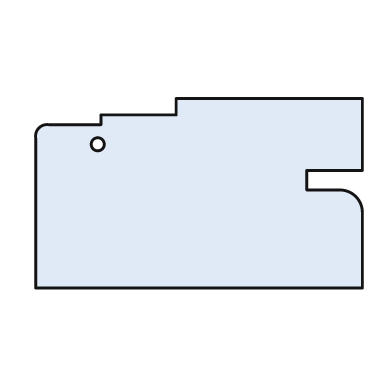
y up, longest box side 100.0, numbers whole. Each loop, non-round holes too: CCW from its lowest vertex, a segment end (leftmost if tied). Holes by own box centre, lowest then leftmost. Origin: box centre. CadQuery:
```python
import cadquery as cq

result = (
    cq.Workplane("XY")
    .moveTo(-50.0, -29.0)
    .lineTo(50.0, -29.0)
    .lineTo(50.0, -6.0)
    .threePointArc((48.0, -1.0), (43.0, 1.0))
    .lineTo(33.0, 1.0)
    .lineTo(33.0, 7.0)
    .lineTo(50.0, 7.0)
    .lineTo(50.0, 29.0)
    .lineTo(-7.0, 29.0)
    .lineTo(-7.0, 24.0)
    .lineTo(-30.0, 24.0)
    .lineTo(-30.0, 21.0)
    .lineTo(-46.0, 21.0)
    .threePointArc((-49.0, 20.0), (-50.0, 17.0))
    .close()
    .moveTo(-31.0, 15.0)
    .circle(2.0)
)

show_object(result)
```